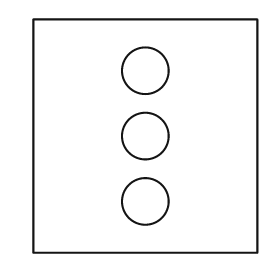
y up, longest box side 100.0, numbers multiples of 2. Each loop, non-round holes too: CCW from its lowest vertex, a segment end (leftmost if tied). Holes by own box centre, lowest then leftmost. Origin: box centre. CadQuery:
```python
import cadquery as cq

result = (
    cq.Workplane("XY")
    .moveTo(-48.0, -50.0)
    .lineTo(48.0, -50.0)
    .lineTo(48.0, 50.0)
    .lineTo(-48.0, 50.0)
    .close()
    .moveTo(0.0, -28.0)
    .circle(10.0)
    .moveTo(0.0, 0.0)
    .circle(10.0)
    .moveTo(0.0, 28.0)
    .circle(10.0)
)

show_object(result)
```